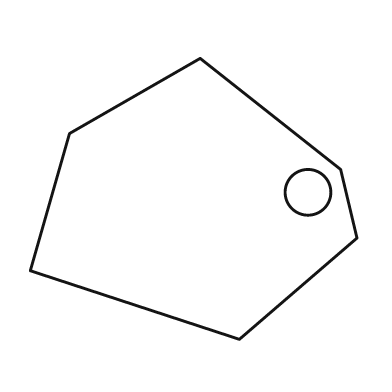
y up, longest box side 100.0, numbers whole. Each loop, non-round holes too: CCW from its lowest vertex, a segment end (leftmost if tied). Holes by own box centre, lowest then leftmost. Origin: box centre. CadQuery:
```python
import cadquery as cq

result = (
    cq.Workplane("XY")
    .moveTo(14.0, -43.0)
    .lineTo(50.0, -12.0)
    .lineTo(45.0, 9.0)
    .lineTo(2.0, 43.0)
    .lineTo(-38.0, 20.0)
    .lineTo(-50.0, -22.0)
    .close()
    .moveTo(35.0, 2.0)
    .circle(7.0)
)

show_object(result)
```